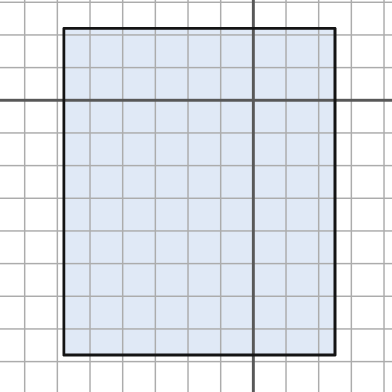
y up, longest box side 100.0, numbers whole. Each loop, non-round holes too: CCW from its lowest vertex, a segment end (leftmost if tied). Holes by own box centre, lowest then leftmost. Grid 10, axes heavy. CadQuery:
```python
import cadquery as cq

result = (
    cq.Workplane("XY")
    .moveTo(-58.0, -78.0)
    .lineTo(25.0, -78.0)
    .lineTo(25.0, 22.0)
    .lineTo(-58.0, 22.0)
    .close()
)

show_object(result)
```